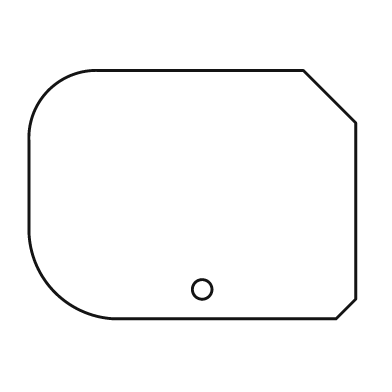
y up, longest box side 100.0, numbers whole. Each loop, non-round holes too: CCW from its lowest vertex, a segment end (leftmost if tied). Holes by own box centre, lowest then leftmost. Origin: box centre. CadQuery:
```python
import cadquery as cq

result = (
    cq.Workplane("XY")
    .moveTo(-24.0, -38.0)
    .lineTo(44.0, -38.0)
    .lineTo(50.0, -32.0)
    .lineTo(50.0, 22.0)
    .lineTo(34.0, 38.0)
    .lineTo(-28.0, 38.0)
    .threePointArc((-44.0, 32.0), (-50.0, 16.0))
    .lineTo(-50.0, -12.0)
    .threePointArc((-42.0, -30.0), (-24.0, -38.0))
    .close()
    .moveTo(3.0, -29.0)
    .circle(3.0)
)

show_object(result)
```